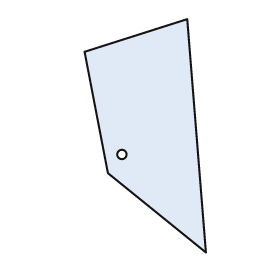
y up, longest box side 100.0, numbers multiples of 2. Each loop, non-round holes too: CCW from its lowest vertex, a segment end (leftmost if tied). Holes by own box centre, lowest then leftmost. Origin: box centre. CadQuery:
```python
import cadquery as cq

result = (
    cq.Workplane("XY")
    .moveTo(26.0, -50.0)
    .lineTo(18.0, 50.0)
    .lineTo(-26.0, 36.0)
    .lineTo(-16.0, -16.0)
    .close()
    .moveTo(-10.0, -8.0)
    .circle(2.0)
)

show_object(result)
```